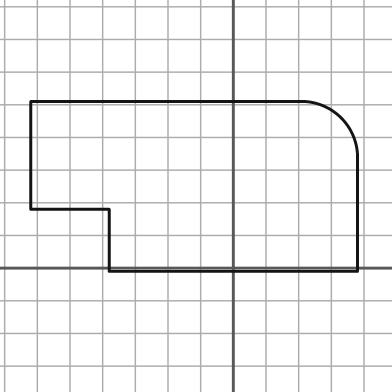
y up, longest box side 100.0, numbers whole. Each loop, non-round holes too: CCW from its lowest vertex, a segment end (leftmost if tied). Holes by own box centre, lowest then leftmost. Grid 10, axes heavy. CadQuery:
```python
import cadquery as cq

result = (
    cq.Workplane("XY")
    .moveTo(-38.0, -1.0)
    .lineTo(38.0, -1.0)
    .lineTo(38.0, 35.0)
    .threePointArc((33.0, 46.0), (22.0, 51.0))
    .lineTo(-62.0, 51.0)
    .lineTo(-62.0, 18.0)
    .lineTo(-38.0, 18.0)
    .close()
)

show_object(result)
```